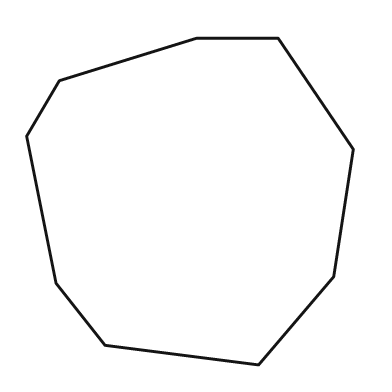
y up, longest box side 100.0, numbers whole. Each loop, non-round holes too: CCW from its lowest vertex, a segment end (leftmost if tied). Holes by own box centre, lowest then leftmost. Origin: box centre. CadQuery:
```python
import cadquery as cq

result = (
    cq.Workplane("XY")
    .moveTo(21.0, -50.0)
    .lineTo(44.0, -23.0)
    .lineTo(50.0, 16.0)
    .lineTo(27.0, 50.0)
    .lineTo(2.0, 50.0)
    .lineTo(-40.0, 37.0)
    .lineTo(-50.0, 20.0)
    .lineTo(-41.0, -25.0)
    .lineTo(-26.0, -44.0)
    .close()
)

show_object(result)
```